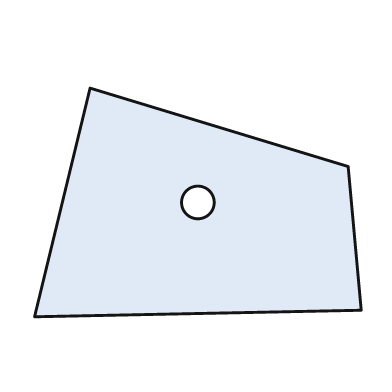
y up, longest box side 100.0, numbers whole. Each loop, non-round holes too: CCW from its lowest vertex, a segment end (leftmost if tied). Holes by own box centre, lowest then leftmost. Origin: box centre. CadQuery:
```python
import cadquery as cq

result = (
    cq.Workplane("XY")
    .moveTo(-50.0, -35.0)
    .lineTo(50.0, -33.0)
    .lineTo(46.0, 11.0)
    .lineTo(-33.0, 35.0)
    .close()
    .moveTo(0.0, 0.0)
    .circle(5.0)
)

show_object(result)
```